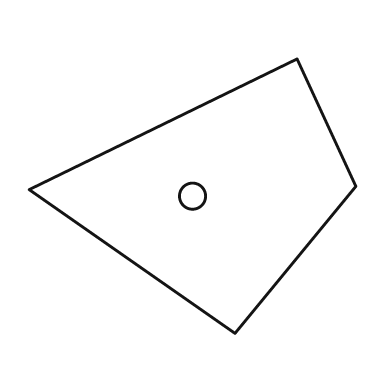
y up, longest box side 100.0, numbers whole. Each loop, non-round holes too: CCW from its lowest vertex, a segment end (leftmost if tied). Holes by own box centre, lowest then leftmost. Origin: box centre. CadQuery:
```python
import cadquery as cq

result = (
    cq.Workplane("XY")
    .moveTo(13.0, -42.0)
    .lineTo(50.0, 3.0)
    .lineTo(32.0, 42.0)
    .lineTo(-50.0, 2.0)
    .close()
    .moveTo(0.0, 0.0)
    .circle(4.0)
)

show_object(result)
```